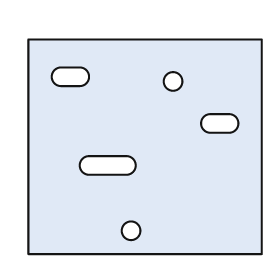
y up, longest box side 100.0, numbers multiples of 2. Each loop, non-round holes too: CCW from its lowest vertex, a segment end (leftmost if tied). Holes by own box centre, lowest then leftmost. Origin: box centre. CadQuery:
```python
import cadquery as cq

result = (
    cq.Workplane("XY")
    .moveTo(-50.0, -46.0)
    .lineTo(50.0, -46.0)
    .lineTo(50.0, 46.0)
    .lineTo(-50.0, 46.0)
    .close()
    .moveTo(-6.0, -36.0)
    .circle(4.0)
    .moveTo(-24.0, -12.0)
    .lineTo(-8.0, -12.0)
    .threePointArc((-4.0, -8.0), (-8.0, -4.0))
    .lineTo(-24.0, -4.0)
    .threePointArc((-28.0, -8.0), (-24.0, -12.0))
    .close()
    .moveTo(28.0, 6.0)
    .lineTo(36.0, 6.0)
    .threePointArc((40.0, 10.0), (36.0, 14.0))
    .lineTo(28.0, 14.0)
    .threePointArc((24.0, 10.0), (28.0, 6.0))
    .close()
    .moveTo(12.0, 28.0)
    .circle(4.0)
    .moveTo(-36.0, 26.0)
    .lineTo(-28.0, 26.0)
    .threePointArc((-24.0, 30.0), (-28.0, 34.0))
    .lineTo(-36.0, 34.0)
    .threePointArc((-40.0, 30.0), (-36.0, 26.0))
    .close()
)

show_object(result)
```